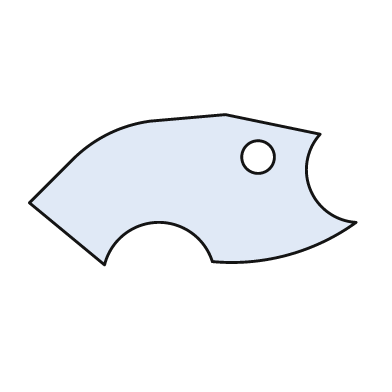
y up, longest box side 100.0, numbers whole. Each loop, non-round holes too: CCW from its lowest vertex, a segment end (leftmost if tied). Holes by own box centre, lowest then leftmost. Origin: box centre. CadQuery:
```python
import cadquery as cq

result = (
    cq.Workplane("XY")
    .moveTo(-27.0, -23.0)
    .threePointArc((-11.0, -10.0), (6.0, -22.0))
    .threePointArc((29.0, -20.0), (50.0, -10.0))
    .threePointArc((36.0, 0.0), (39.0, 17.0))
    .lineTo(10.0, 23.0)
    .lineTo(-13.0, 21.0)
    .threePointArc((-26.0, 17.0), (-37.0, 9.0))
    .lineTo(-50.0, -4.0)
    .close()
    .moveTo(20.0, 10.0)
    .circle(5.0)
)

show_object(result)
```